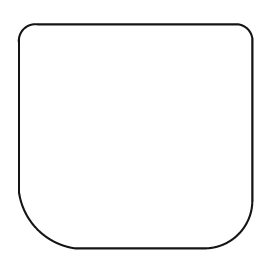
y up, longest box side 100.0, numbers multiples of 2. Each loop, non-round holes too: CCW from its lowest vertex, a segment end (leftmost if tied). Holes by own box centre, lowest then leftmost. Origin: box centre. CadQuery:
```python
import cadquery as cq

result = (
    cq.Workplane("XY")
    .moveTo(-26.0, -48.0)
    .lineTo(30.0, -48.0)
    .threePointArc((44.0, -42.0), (50.0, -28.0))
    .lineTo(50.0, 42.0)
    .threePointArc((48.0, 46.0), (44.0, 48.0))
    .lineTo(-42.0, 48.0)
    .threePointArc((-48.0, 46.0), (-50.0, 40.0))
    .lineTo(-50.0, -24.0)
    .threePointArc((-42.0, -40.0), (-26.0, -48.0))
    .close()
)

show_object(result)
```